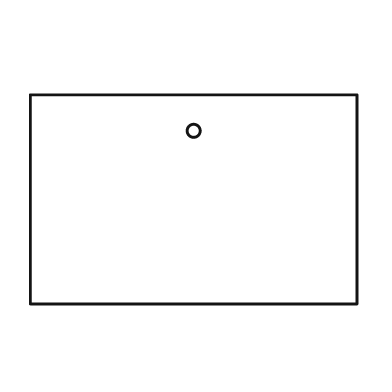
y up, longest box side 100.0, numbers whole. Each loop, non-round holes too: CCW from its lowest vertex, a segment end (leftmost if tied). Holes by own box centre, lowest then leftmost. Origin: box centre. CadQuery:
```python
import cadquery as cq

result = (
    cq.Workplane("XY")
    .moveTo(-50.0, -32.0)
    .lineTo(50.0, -32.0)
    .lineTo(50.0, 32.0)
    .lineTo(-50.0, 32.0)
    .close()
    .moveTo(0.0, 21.0)
    .circle(2.0)
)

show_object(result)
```